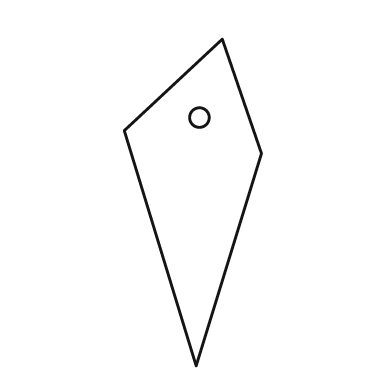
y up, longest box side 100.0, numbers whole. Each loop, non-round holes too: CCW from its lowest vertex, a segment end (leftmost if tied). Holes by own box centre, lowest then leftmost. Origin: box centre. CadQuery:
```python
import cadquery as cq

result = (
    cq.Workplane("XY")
    .moveTo(1.0, -50.0)
    .lineTo(21.0, 15.0)
    .lineTo(9.0, 50.0)
    .lineTo(-21.0, 22.0)
    .close()
    .moveTo(2.0, 26.0)
    .circle(3.0)
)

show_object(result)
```